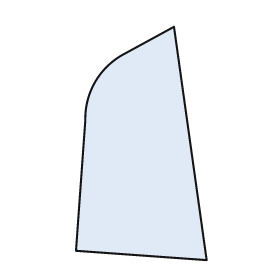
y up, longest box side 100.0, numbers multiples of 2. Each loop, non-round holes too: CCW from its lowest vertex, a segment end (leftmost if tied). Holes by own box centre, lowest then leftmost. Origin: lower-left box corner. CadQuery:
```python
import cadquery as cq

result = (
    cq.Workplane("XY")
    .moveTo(56.0, 0.0)
    .lineTo(42.0, 100.0)
    .lineTo(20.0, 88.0)
    .threePointArc((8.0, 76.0), (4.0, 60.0))
    .lineTo(0.0, 4.0)
    .close()
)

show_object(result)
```